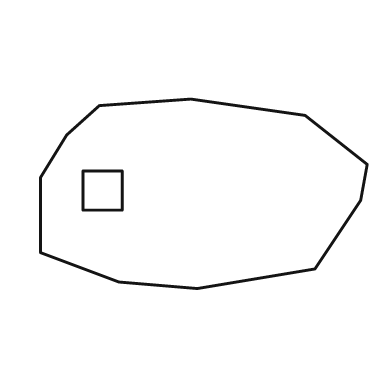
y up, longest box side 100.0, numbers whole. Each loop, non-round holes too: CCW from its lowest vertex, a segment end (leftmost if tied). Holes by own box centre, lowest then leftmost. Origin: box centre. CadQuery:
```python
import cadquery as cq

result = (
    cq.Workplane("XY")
    .moveTo(-2.0, -29.0)
    .lineTo(34.0, -23.0)
    .lineTo(48.0, -2.0)
    .lineTo(50.0, 9.0)
    .lineTo(31.0, 24.0)
    .lineTo(-4.0, 29.0)
    .lineTo(-32.0, 27.0)
    .lineTo(-42.0, 18.0)
    .lineTo(-50.0, 5.0)
    .lineTo(-50.0, -18.0)
    .lineTo(-26.0, -27.0)
    .close()
    .moveTo(-37.0, -5.0)
    .lineTo(-25.0, -5.0)
    .lineTo(-25.0, 7.0)
    .lineTo(-37.0, 7.0)
    .close()
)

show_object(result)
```